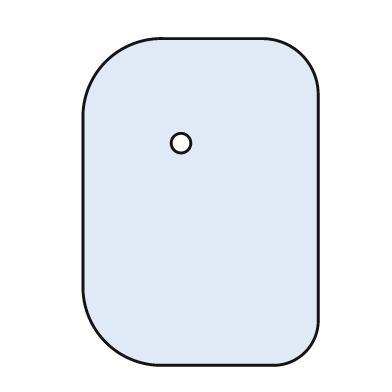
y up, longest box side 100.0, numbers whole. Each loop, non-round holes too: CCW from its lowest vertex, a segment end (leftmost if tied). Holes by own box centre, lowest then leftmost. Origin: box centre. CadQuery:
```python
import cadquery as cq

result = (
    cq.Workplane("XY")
    .moveTo(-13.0, -50.0)
    .lineTo(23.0, -50.0)
    .threePointArc((32.0, -46.0), (36.0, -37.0))
    .lineTo(36.0, 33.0)
    .threePointArc((31.0, 45.0), (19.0, 50.0))
    .lineTo(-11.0, 50.0)
    .threePointArc((-29.0, 43.0), (-36.0, 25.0))
    .lineTo(-36.0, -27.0)
    .threePointArc((-29.0, -43.0), (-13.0, -50.0))
    .close()
    .moveTo(-6.0, 18.0)
    .circle(3.0)
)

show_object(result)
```